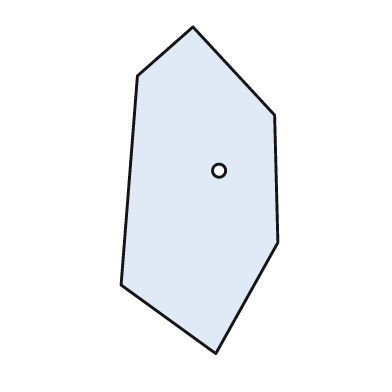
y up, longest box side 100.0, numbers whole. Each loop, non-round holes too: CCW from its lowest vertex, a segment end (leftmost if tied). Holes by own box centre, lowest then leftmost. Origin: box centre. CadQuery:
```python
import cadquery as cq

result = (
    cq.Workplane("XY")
    .moveTo(5.0, -50.0)
    .lineTo(24.0, -16.0)
    .lineTo(23.0, 23.0)
    .lineTo(-2.0, 50.0)
    .lineTo(-19.0, 35.0)
    .lineTo(-24.0, -29.0)
    .close()
    .moveTo(6.0, 6.0)
    .circle(2.0)
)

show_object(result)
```